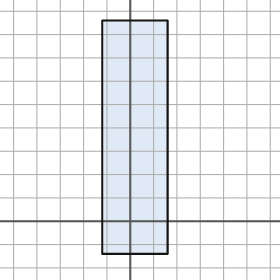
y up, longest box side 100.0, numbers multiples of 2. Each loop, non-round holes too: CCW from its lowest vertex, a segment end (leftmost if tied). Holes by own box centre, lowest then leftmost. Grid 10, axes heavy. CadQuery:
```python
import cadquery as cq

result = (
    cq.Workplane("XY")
    .moveTo(-12.0, -14.0)
    .lineTo(16.0, -14.0)
    .lineTo(16.0, 86.0)
    .lineTo(-12.0, 86.0)
    .close()
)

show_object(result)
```